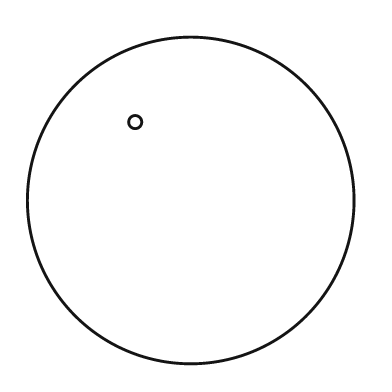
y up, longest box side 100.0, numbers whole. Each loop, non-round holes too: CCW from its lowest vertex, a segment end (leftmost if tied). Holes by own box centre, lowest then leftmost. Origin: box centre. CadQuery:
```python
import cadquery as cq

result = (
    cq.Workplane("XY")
    .moveTo(0.0, 0.0)
    .circle(50.0)
    .moveTo(-17.0, 24.0)
    .circle(2.0)
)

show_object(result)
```